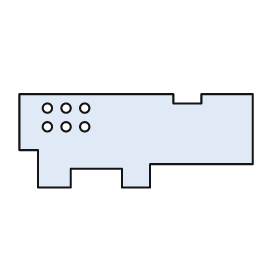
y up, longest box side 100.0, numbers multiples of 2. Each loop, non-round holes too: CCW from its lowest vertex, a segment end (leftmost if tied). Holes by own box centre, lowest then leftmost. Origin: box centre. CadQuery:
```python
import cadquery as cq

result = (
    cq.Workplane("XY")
    .moveTo(-42.0, -20.0)
    .lineTo(-28.0, -20.0)
    .lineTo(-28.0, -12.0)
    .lineTo(-6.0, -12.0)
    .lineTo(-6.0, -20.0)
    .lineTo(6.0, -20.0)
    .lineTo(6.0, -10.0)
    .lineTo(50.0, -10.0)
    .lineTo(50.0, 20.0)
    .lineTo(28.0, 20.0)
    .lineTo(28.0, 16.0)
    .lineTo(16.0, 16.0)
    .lineTo(16.0, 20.0)
    .lineTo(-50.0, 20.0)
    .lineTo(-50.0, -4.0)
    .lineTo(-42.0, -4.0)
    .close()
    .moveTo(-38.0, 6.0)
    .circle(2.0)
    .moveTo(-30.0, 6.0)
    .circle(2.0)
    .moveTo(-22.0, 6.0)
    .circle(2.0)
    .moveTo(-38.0, 14.0)
    .circle(2.0)
    .moveTo(-30.0, 14.0)
    .circle(2.0)
    .moveTo(-22.0, 14.0)
    .circle(2.0)
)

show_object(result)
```